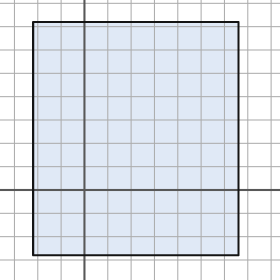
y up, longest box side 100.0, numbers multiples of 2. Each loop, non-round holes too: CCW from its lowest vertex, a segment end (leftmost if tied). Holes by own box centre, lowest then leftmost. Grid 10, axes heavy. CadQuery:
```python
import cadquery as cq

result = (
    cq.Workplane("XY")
    .moveTo(-22.0, -28.0)
    .lineTo(66.0, -28.0)
    .lineTo(66.0, 72.0)
    .lineTo(-22.0, 72.0)
    .close()
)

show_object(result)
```